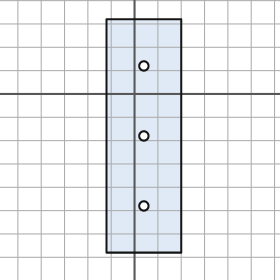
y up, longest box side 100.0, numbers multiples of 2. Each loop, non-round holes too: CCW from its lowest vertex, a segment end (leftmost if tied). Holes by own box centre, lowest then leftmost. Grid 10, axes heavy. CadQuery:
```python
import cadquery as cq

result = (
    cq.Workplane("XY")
    .moveTo(-12.0, -68.0)
    .lineTo(20.0, -68.0)
    .lineTo(20.0, 32.0)
    .lineTo(-12.0, 32.0)
    .close()
    .moveTo(4.0, -48.0)
    .circle(2.0)
    .moveTo(4.0, -18.0)
    .circle(2.0)
    .moveTo(4.0, 12.0)
    .circle(2.0)
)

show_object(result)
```